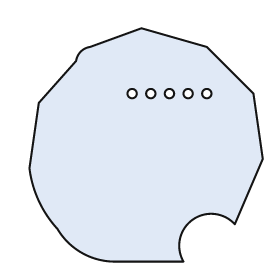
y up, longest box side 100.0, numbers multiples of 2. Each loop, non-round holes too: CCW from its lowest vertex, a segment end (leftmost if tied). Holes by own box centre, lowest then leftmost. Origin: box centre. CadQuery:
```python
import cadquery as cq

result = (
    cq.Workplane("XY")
    .moveTo(-14.0, -50.0)
    .lineTo(16.0, -50.0)
    .threePointArc((20.0, -32.0), (38.0, -34.0))
    .lineTo(50.0, -6.0)
    .lineTo(46.0, 22.0)
    .lineTo(26.0, 42.0)
    .lineTo(-2.0, 50.0)
    .lineTo(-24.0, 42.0)
    .threePointArc((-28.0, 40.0), (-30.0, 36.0))
    .lineTo(-46.0, 18.0)
    .lineTo(-50.0, -10.0)
    .threePointArc((-46.0, -24.0), (-38.0, -36.0))
    .threePointArc((-28.0, -46.0), (-14.0, -50.0))
    .close()
    .moveTo(-6.0, 22.0)
    .circle(2.0)
    .moveTo(2.0, 22.0)
    .circle(2.0)
    .moveTo(10.0, 22.0)
    .circle(2.0)
    .moveTo(18.0, 22.0)
    .circle(2.0)
    .moveTo(26.0, 22.0)
    .circle(2.0)
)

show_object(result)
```